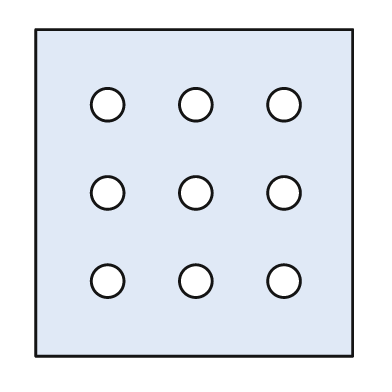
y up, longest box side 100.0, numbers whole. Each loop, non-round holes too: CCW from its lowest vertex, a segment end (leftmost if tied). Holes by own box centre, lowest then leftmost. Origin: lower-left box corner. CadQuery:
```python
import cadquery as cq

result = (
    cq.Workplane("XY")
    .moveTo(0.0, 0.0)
    .lineTo(97.0, 0.0)
    .lineTo(97.0, 100.0)
    .lineTo(0.0, 100.0)
    .close()
    .moveTo(22.0, 23.0)
    .circle(5.0)
    .moveTo(49.0, 23.0)
    .circle(5.0)
    .moveTo(76.0, 23.0)
    .circle(5.0)
    .moveTo(22.0, 50.0)
    .circle(5.0)
    .moveTo(49.0, 50.0)
    .circle(5.0)
    .moveTo(76.0, 50.0)
    .circle(5.0)
    .moveTo(22.0, 77.0)
    .circle(5.0)
    .moveTo(49.0, 77.0)
    .circle(5.0)
    .moveTo(76.0, 77.0)
    .circle(5.0)
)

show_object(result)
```